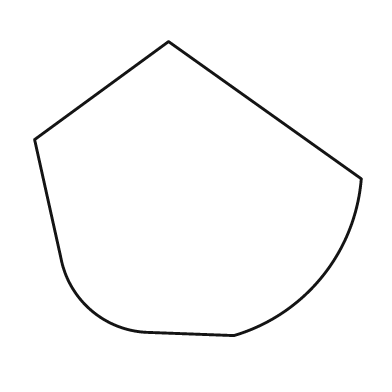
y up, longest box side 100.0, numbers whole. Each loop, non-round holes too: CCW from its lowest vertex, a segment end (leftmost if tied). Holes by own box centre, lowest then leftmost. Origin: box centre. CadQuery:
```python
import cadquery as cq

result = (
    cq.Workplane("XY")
    .moveTo(11.0, -45.0)
    .threePointArc((38.0, -27.0), (50.0, 3.0))
    .lineTo(-9.0, 45.0)
    .lineTo(-50.0, 15.0)
    .lineTo(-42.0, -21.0)
    .threePointArc((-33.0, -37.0), (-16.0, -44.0))
    .close()
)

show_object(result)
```